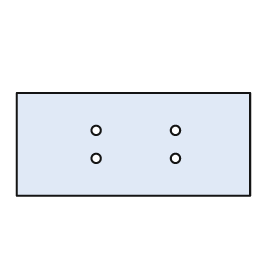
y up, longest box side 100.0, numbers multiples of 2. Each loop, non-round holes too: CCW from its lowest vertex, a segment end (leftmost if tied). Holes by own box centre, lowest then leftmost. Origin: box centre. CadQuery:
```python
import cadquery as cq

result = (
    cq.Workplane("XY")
    .moveTo(-50.0, -22.0)
    .lineTo(50.0, -22.0)
    .lineTo(50.0, 22.0)
    .lineTo(-50.0, 22.0)
    .close()
    .moveTo(-16.0, -6.0)
    .circle(2.0)
    .moveTo(18.0, -6.0)
    .circle(2.0)
    .moveTo(-16.0, 6.0)
    .circle(2.0)
    .moveTo(18.0, 6.0)
    .circle(2.0)
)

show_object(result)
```